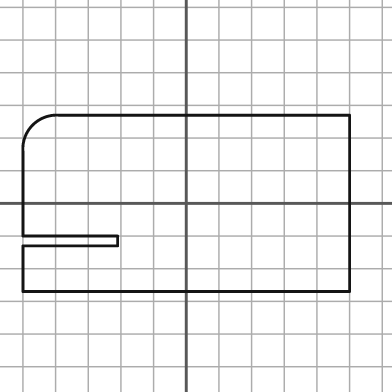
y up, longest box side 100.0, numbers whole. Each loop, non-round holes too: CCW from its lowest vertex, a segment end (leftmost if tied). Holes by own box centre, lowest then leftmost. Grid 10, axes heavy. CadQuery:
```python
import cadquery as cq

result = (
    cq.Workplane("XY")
    .moveTo(-50.0, -27.0)
    .lineTo(50.0, -27.0)
    .lineTo(50.0, 27.0)
    .lineTo(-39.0, 27.0)
    .threePointArc((-47.0, 24.0), (-50.0, 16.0))
    .lineTo(-50.0, -10.0)
    .lineTo(-21.0, -10.0)
    .lineTo(-21.0, -13.0)
    .lineTo(-50.0, -13.0)
    .close()
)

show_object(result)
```